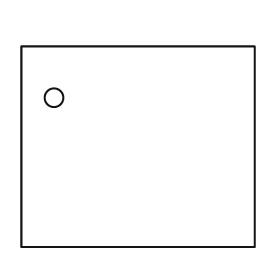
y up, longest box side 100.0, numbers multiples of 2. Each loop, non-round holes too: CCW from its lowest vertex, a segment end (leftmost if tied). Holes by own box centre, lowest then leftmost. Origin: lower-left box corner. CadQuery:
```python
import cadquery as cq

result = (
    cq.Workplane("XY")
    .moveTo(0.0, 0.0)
    .lineTo(100.0, 0.0)
    .lineTo(100.0, 86.0)
    .lineTo(0.0, 86.0)
    .close()
    .moveTo(14.0, 64.0)
    .circle(4.0)
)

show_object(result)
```